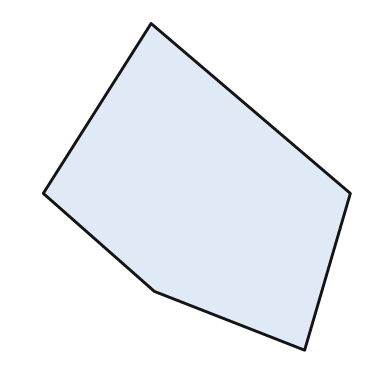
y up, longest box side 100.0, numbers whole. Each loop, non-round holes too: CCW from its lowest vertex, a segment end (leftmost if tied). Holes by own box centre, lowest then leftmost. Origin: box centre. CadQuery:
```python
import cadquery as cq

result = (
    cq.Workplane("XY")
    .moveTo(33.0, -50.0)
    .lineTo(47.0, -2.0)
    .lineTo(-14.0, 50.0)
    .lineTo(-47.0, -2.0)
    .lineTo(-13.0, -32.0)
    .close()
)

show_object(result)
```